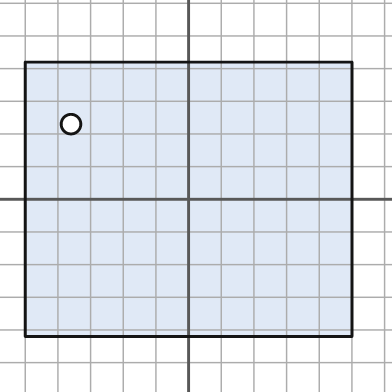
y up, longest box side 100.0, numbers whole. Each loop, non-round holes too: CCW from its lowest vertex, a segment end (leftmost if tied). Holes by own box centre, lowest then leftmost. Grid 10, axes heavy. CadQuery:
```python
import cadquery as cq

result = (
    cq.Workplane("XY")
    .moveTo(-50.0, -42.0)
    .lineTo(50.0, -42.0)
    .lineTo(50.0, 42.0)
    .lineTo(-50.0, 42.0)
    .close()
    .moveTo(-36.0, 23.0)
    .circle(3.0)
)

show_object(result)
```